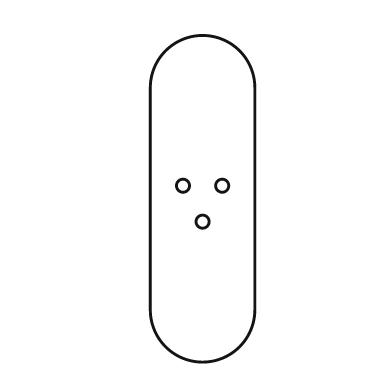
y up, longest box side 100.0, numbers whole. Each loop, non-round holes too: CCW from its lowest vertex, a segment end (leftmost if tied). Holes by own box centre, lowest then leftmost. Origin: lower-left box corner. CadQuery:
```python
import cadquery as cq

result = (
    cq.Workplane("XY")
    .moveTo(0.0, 16.0)
    .threePointArc((16.0, 0.0), (32.0, 16.0))
    .lineTo(32.0, 84.0)
    .threePointArc((16.0, 100.0), (0.0, 84.0))
    .close()
    .moveTo(16.0, 43.0)
    .circle(2.0)
    .moveTo(10.0, 54.0)
    .circle(2.0)
    .moveTo(22.0, 54.0)
    .circle(2.0)
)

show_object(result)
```